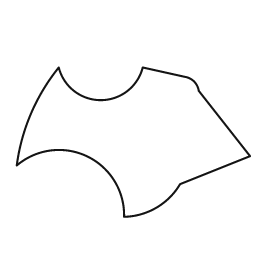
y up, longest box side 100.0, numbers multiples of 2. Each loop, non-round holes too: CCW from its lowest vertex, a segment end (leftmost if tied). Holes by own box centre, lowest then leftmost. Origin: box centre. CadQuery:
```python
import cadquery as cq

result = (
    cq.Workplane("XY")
    .moveTo(-4.0, -32.0)
    .threePointArc((10.0, -28.0), (20.0, -18.0))
    .lineTo(50.0, -6.0)
    .lineTo(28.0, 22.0)
    .threePointArc((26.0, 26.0), (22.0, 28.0))
    .lineTo(4.0, 32.0)
    .threePointArc((-14.0, 18.0), (-32.0, 32.0))
    .threePointArc((-44.0, 12.0), (-50.0, -10.0))
    .threePointArc((-20.0, -6.0), (-4.0, -32.0))
    .close()
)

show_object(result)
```